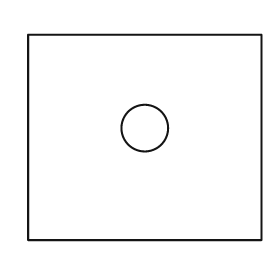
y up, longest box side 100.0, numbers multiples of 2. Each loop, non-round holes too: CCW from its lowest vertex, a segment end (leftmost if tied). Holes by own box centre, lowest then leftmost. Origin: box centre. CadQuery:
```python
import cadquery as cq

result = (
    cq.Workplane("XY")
    .moveTo(-50.0, -44.0)
    .lineTo(50.0, -44.0)
    .lineTo(50.0, 44.0)
    .lineTo(-50.0, 44.0)
    .close()
    .moveTo(0.0, 4.0)
    .circle(10.0)
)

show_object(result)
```